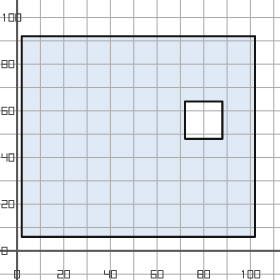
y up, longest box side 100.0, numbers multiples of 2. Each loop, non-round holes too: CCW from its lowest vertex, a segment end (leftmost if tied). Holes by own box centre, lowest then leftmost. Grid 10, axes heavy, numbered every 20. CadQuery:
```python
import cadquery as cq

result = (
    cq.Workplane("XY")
    .moveTo(2.0, 6.0)
    .lineTo(102.0, 6.0)
    .lineTo(102.0, 92.0)
    .lineTo(2.0, 92.0)
    .close()
    .moveTo(72.0, 48.0)
    .lineTo(88.0, 48.0)
    .lineTo(88.0, 64.0)
    .lineTo(72.0, 64.0)
    .close()
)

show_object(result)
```